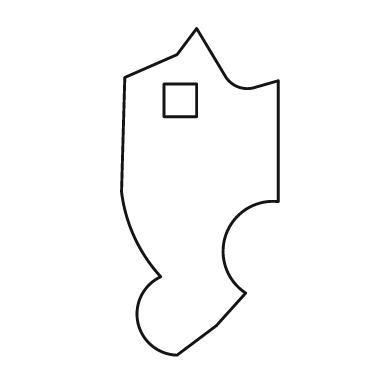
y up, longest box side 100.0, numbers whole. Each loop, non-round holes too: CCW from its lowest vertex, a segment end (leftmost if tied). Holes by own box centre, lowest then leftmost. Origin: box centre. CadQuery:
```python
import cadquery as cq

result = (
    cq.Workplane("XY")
    .moveTo(-7.0, -50.0)
    .lineTo(5.0, -41.0)
    .lineTo(14.0, -31.0)
    .threePointArc((8.0, -13.0), (24.0, -3.0))
    .lineTo(24.0, 34.0)
    .lineTo(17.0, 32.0)
    .threePointArc((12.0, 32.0), (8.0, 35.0))
    .lineTo(-1.0, 50.0)
    .lineTo(-7.0, 42.0)
    .lineTo(-23.0, 35.0)
    .lineTo(-24.0, 0.0)
    .threePointArc((-20.0, -14.0), (-12.0, -26.0))
    .threePointArc((-19.0, -40.0), (-7.0, -50.0))
    .close()
    .moveTo(-11.0, 23.0)
    .lineTo(-1.0, 23.0)
    .lineTo(-1.0, 33.0)
    .lineTo(-11.0, 33.0)
    .close()
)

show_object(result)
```